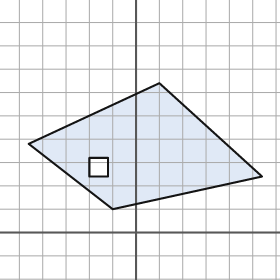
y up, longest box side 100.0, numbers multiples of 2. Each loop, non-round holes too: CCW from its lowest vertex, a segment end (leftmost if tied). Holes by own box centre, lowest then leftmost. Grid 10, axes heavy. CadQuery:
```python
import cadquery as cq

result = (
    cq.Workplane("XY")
    .moveTo(-10.0, 10.0)
    .lineTo(54.0, 24.0)
    .lineTo(10.0, 64.0)
    .lineTo(-46.0, 38.0)
    .close()
    .moveTo(-20.0, 24.0)
    .lineTo(-12.0, 24.0)
    .lineTo(-12.0, 32.0)
    .lineTo(-20.0, 32.0)
    .close()
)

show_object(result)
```